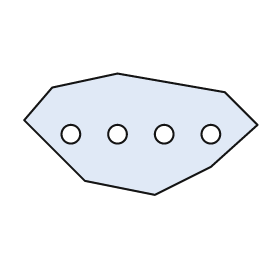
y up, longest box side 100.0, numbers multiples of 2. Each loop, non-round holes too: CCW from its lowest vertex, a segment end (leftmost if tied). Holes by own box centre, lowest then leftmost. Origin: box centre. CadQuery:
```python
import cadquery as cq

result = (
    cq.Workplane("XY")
    .moveTo(6.0, -26.0)
    .lineTo(30.0, -14.0)
    .lineTo(50.0, 4.0)
    .lineTo(36.0, 18.0)
    .lineTo(-10.0, 26.0)
    .lineTo(-38.0, 20.0)
    .lineTo(-50.0, 6.0)
    .lineTo(-24.0, -20.0)
    .close()
    .moveTo(-30.0, 0.0)
    .circle(4.0)
    .moveTo(-10.0, 0.0)
    .circle(4.0)
    .moveTo(10.0, 0.0)
    .circle(4.0)
    .moveTo(30.0, 0.0)
    .circle(4.0)
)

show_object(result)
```